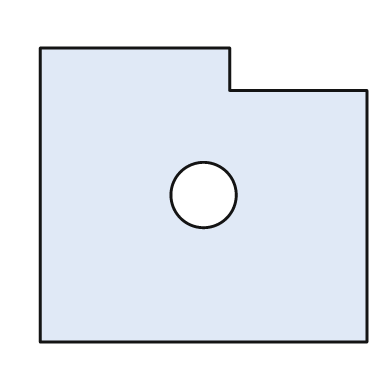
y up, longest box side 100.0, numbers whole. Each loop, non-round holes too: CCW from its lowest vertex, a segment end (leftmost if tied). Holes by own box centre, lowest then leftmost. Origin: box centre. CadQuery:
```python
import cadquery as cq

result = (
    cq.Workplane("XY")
    .moveTo(-50.0, -45.0)
    .lineTo(50.0, -45.0)
    .lineTo(50.0, 32.0)
    .lineTo(8.0, 32.0)
    .lineTo(8.0, 45.0)
    .lineTo(-50.0, 45.0)
    .close()
    .moveTo(0.0, 0.0)
    .circle(10.0)
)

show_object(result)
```